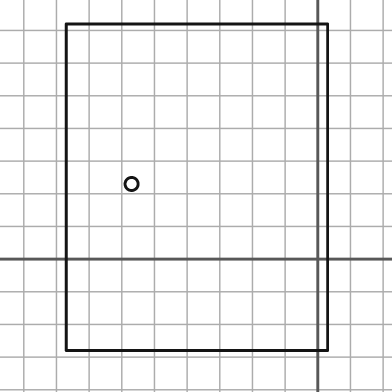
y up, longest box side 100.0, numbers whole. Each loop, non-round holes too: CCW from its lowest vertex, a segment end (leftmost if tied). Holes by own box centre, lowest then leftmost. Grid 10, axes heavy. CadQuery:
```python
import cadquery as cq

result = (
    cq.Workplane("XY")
    .moveTo(-77.0, -28.0)
    .lineTo(3.0, -28.0)
    .lineTo(3.0, 72.0)
    .lineTo(-77.0, 72.0)
    .close()
    .moveTo(-57.0, 23.0)
    .circle(2.0)
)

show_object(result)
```